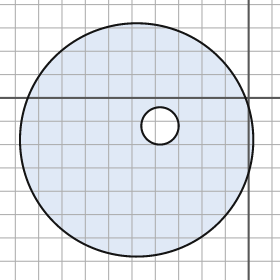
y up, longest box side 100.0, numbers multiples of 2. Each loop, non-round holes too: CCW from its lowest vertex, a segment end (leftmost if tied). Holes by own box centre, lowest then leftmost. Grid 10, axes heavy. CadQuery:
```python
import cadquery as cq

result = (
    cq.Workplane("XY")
    .moveTo(-48.0, -18.0)
    .circle(50.0)
    .moveTo(-38.0, -12.0)
    .circle(8.0)
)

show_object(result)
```